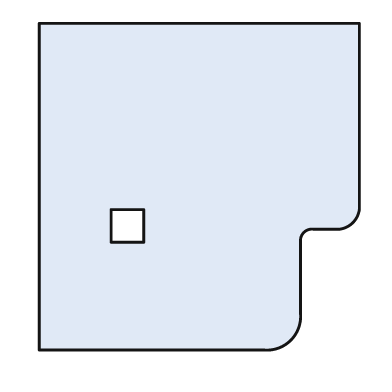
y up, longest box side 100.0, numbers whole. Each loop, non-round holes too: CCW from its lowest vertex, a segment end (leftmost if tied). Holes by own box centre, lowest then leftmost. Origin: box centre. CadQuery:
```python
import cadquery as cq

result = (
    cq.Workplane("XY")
    .moveTo(-49.0, -50.0)
    .lineTo(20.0, -50.0)
    .threePointArc((28.0, -47.0), (31.0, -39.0))
    .lineTo(31.0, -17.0)
    .threePointArc((32.0, -14.0), (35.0, -13.0))
    .lineTo(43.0, -13.0)
    .threePointArc((47.0, -11.0), (49.0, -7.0))
    .lineTo(49.0, 50.0)
    .lineTo(-49.0, 50.0)
    .close()
    .moveTo(-27.0, -17.0)
    .lineTo(-17.0, -17.0)
    .lineTo(-17.0, -7.0)
    .lineTo(-27.0, -7.0)
    .close()
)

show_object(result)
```